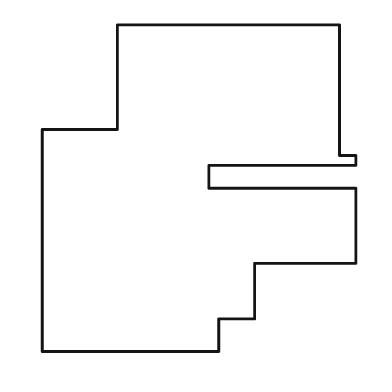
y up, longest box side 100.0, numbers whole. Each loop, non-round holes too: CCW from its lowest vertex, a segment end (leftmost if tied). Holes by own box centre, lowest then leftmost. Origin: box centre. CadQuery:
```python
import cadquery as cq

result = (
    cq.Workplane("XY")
    .moveTo(-48.0, -50.0)
    .lineTo(6.0, -50.0)
    .lineTo(6.0, -40.0)
    .lineTo(17.0, -40.0)
    .lineTo(17.0, -23.0)
    .lineTo(48.0, -23.0)
    .lineTo(48.0, 0.0)
    .lineTo(3.0, 0.0)
    .lineTo(3.0, 7.0)
    .lineTo(48.0, 7.0)
    .lineTo(48.0, 10.0)
    .lineTo(43.0, 10.0)
    .lineTo(43.0, 50.0)
    .lineTo(-25.0, 50.0)
    .lineTo(-25.0, 18.0)
    .lineTo(-48.0, 18.0)
    .close()
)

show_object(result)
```